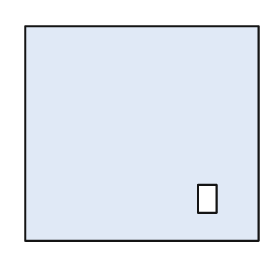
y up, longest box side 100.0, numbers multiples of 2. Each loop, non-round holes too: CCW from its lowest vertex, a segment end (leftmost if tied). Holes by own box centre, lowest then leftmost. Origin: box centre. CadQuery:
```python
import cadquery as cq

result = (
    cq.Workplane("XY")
    .moveTo(-50.0, -46.0)
    .lineTo(50.0, -46.0)
    .lineTo(50.0, 46.0)
    .lineTo(-50.0, 46.0)
    .close()
    .moveTo(24.0, -34.0)
    .lineTo(32.0, -34.0)
    .lineTo(32.0, -22.0)
    .lineTo(24.0, -22.0)
    .close()
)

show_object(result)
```